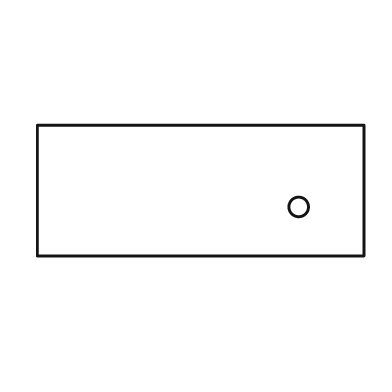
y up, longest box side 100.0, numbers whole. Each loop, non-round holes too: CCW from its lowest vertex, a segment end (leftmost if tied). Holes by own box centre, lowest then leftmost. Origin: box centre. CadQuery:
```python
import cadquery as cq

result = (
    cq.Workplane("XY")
    .moveTo(-50.0, -20.0)
    .lineTo(50.0, -20.0)
    .lineTo(50.0, 20.0)
    .lineTo(-50.0, 20.0)
    .close()
    .moveTo(30.0, -5.0)
    .circle(3.0)
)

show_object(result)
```